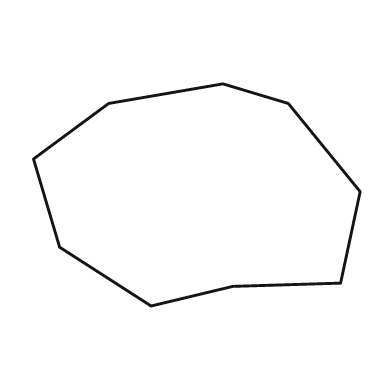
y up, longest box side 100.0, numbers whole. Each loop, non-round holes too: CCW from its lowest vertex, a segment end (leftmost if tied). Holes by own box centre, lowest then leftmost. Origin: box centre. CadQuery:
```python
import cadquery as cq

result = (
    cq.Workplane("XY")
    .moveTo(-14.0, -34.0)
    .lineTo(11.0, -28.0)
    .lineTo(44.0, -27.0)
    .lineTo(50.0, 1.0)
    .lineTo(28.0, 28.0)
    .lineTo(8.0, 34.0)
    .lineTo(-27.0, 28.0)
    .lineTo(-50.0, 11.0)
    .lineTo(-42.0, -16.0)
    .close()
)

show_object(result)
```